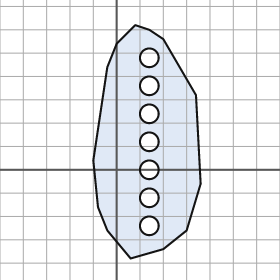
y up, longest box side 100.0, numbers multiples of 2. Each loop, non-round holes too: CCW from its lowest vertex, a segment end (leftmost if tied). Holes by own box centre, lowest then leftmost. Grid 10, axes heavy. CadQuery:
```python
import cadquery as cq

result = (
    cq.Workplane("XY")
    .moveTo(6.0, -38.0)
    .lineTo(20.0, -34.0)
    .lineTo(30.0, -26.0)
    .lineTo(36.0, -6.0)
    .lineTo(34.0, 32.0)
    .lineTo(20.0, 56.0)
    .lineTo(14.0, 60.0)
    .lineTo(8.0, 62.0)
    .lineTo(0.0, 54.0)
    .lineTo(-4.0, 44.0)
    .lineTo(-10.0, 4.0)
    .lineTo(-8.0, -16.0)
    .lineTo(-4.0, -26.0)
    .close()
    .moveTo(14.0, -24.0)
    .circle(4.0)
    .moveTo(14.0, -12.0)
    .circle(4.0)
    .moveTo(14.0, 0.0)
    .circle(4.0)
    .moveTo(14.0, 12.0)
    .circle(4.0)
    .moveTo(14.0, 24.0)
    .circle(4.0)
    .moveTo(14.0, 36.0)
    .circle(4.0)
    .moveTo(14.0, 48.0)
    .circle(4.0)
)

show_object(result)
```